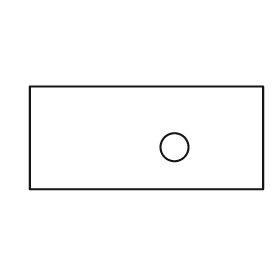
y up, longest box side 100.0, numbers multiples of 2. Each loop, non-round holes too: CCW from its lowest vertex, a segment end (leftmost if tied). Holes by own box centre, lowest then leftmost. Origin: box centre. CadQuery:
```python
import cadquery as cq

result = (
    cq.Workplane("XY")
    .moveTo(-50.0, -22.0)
    .lineTo(50.0, -22.0)
    .lineTo(50.0, 22.0)
    .lineTo(-50.0, 22.0)
    .close()
    .moveTo(12.0, -4.0)
    .circle(6.0)
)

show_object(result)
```